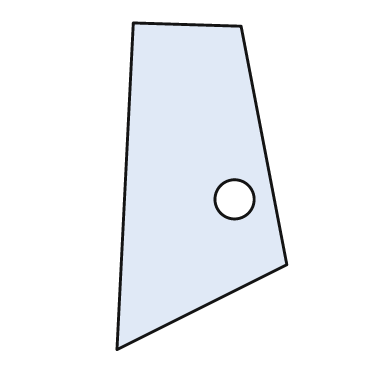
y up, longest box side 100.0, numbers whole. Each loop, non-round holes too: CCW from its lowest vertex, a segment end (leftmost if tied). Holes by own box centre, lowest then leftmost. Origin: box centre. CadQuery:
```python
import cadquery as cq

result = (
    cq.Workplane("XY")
    .moveTo(-26.0, -50.0)
    .lineTo(26.0, -24.0)
    .lineTo(12.0, 49.0)
    .lineTo(-21.0, 50.0)
    .close()
    .moveTo(10.0, -4.0)
    .circle(6.0)
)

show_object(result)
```